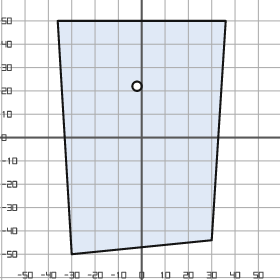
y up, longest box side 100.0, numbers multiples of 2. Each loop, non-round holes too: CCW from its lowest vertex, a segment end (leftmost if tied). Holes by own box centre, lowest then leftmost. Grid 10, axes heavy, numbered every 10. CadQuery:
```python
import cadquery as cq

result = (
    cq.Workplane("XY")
    .moveTo(-30.0, -50.0)
    .lineTo(30.0, -44.0)
    .lineTo(36.0, 50.0)
    .lineTo(-36.0, 50.0)
    .close()
    .moveTo(-2.0, 22.0)
    .circle(2.0)
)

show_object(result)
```